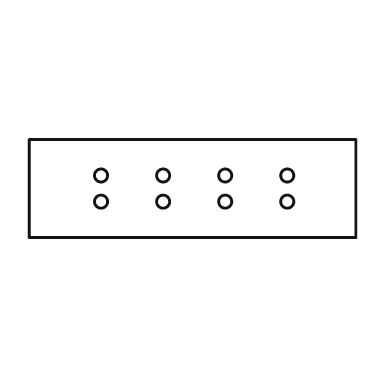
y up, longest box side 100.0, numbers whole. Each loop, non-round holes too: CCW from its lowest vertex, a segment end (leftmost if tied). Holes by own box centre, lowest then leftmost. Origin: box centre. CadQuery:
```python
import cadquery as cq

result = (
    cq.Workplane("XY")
    .moveTo(-50.0, -15.0)
    .lineTo(50.0, -15.0)
    .lineTo(50.0, 15.0)
    .lineTo(-50.0, 15.0)
    .close()
    .moveTo(-28.0, -4.0)
    .circle(2.0)
    .moveTo(-9.0, -4.0)
    .circle(2.0)
    .moveTo(10.0, -4.0)
    .circle(2.0)
    .moveTo(29.0, -4.0)
    .circle(2.0)
    .moveTo(-28.0, 4.0)
    .circle(2.0)
    .moveTo(-9.0, 4.0)
    .circle(2.0)
    .moveTo(10.0, 4.0)
    .circle(2.0)
    .moveTo(29.0, 4.0)
    .circle(2.0)
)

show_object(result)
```